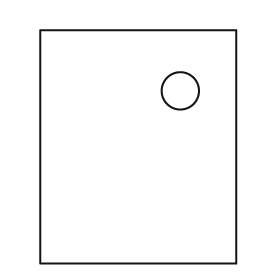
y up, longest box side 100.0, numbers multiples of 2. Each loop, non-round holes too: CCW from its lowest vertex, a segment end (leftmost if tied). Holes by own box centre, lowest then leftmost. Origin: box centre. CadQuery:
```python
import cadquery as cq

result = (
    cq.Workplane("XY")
    .moveTo(-42.0, -50.0)
    .lineTo(42.0, -50.0)
    .lineTo(42.0, 50.0)
    .lineTo(-42.0, 50.0)
    .close()
    .moveTo(18.0, 24.0)
    .circle(8.0)
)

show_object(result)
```